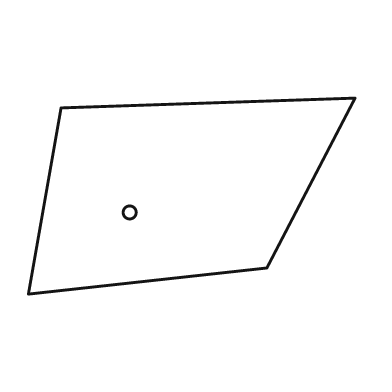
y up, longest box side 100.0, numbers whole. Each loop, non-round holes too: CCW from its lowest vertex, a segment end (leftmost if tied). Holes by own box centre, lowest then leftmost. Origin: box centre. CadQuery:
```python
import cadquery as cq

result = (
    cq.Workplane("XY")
    .moveTo(-50.0, -30.0)
    .lineTo(23.0, -22.0)
    .lineTo(50.0, 30.0)
    .lineTo(-40.0, 27.0)
    .close()
    .moveTo(-19.0, -5.0)
    .circle(2.0)
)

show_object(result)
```